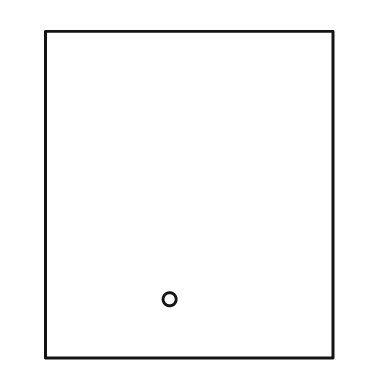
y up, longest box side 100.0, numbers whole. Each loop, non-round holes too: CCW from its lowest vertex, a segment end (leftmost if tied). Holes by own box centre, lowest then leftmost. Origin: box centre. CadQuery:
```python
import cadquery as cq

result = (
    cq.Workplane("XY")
    .moveTo(-44.0, -50.0)
    .lineTo(44.0, -50.0)
    .lineTo(44.0, 50.0)
    .lineTo(-44.0, 50.0)
    .close()
    .moveTo(-6.0, -32.0)
    .circle(2.0)
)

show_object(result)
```